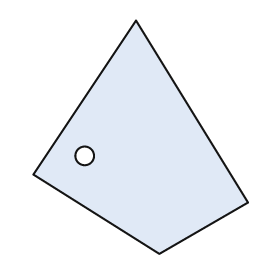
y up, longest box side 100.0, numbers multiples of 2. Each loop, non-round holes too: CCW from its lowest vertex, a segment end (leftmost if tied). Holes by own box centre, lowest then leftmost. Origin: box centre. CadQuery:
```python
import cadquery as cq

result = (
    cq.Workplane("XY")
    .moveTo(8.0, -50.0)
    .lineTo(46.0, -28.0)
    .lineTo(-2.0, 50.0)
    .lineTo(-46.0, -16.0)
    .close()
    .moveTo(-24.0, -8.0)
    .circle(4.0)
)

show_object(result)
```